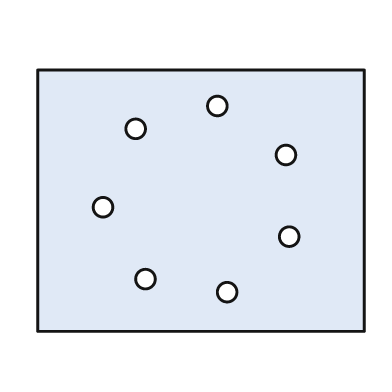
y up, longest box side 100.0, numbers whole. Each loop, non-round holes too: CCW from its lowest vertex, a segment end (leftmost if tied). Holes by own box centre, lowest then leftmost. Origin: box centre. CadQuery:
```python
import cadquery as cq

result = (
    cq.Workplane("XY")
    .moveTo(-50.0, -40.0)
    .lineTo(50.0, -40.0)
    .lineTo(50.0, 40.0)
    .lineTo(-50.0, 40.0)
    .close()
    .moveTo(8.0, -28.0)
    .circle(3.0)
    .moveTo(-17.0, -24.0)
    .circle(3.0)
    .moveTo(27.0, -11.0)
    .circle(3.0)
    .moveTo(-30.0, -2.0)
    .circle(3.0)
    .moveTo(26.0, 14.0)
    .circle(3.0)
    .moveTo(-20.0, 22.0)
    .circle(3.0)
    .moveTo(5.0, 29.0)
    .circle(3.0)
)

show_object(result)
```